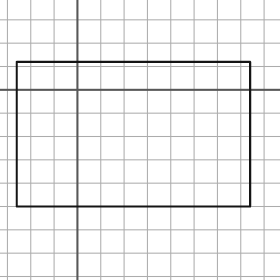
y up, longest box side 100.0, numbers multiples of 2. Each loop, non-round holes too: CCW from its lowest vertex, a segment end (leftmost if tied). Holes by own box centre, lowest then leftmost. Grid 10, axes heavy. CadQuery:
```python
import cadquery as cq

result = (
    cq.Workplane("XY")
    .moveTo(-26.0, -50.0)
    .lineTo(74.0, -50.0)
    .lineTo(74.0, 12.0)
    .lineTo(-26.0, 12.0)
    .close()
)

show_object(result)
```